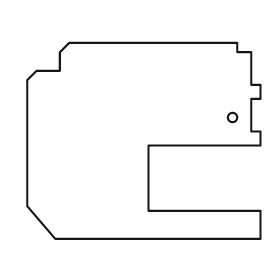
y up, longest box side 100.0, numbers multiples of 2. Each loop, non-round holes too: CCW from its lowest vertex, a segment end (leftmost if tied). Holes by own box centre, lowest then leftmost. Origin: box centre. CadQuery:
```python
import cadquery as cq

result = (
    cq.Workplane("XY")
    .moveTo(-38.0, -42.0)
    .lineTo(50.0, -42.0)
    .lineTo(50.0, -30.0)
    .lineTo(2.0, -30.0)
    .lineTo(2.0, -2.0)
    .lineTo(50.0, -2.0)
    .lineTo(50.0, 4.0)
    .lineTo(46.0, 4.0)
    .lineTo(46.0, 18.0)
    .lineTo(50.0, 18.0)
    .lineTo(50.0, 24.0)
    .lineTo(46.0, 24.0)
    .lineTo(46.0, 38.0)
    .lineTo(40.0, 38.0)
    .lineTo(40.0, 42.0)
    .lineTo(-32.0, 42.0)
    .lineTo(-36.0, 38.0)
    .lineTo(-36.0, 30.0)
    .lineTo(-46.0, 30.0)
    .lineTo(-50.0, 26.0)
    .lineTo(-50.0, -28.0)
    .close()
    .moveTo(38.0, 10.0)
    .circle(2.0)
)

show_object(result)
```